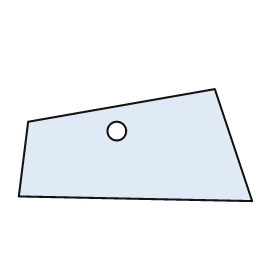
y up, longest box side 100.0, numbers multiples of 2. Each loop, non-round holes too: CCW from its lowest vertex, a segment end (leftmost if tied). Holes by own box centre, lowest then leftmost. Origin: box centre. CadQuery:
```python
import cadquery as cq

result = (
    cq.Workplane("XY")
    .moveTo(50.0, -24.0)
    .lineTo(34.0, 24.0)
    .lineTo(-46.0, 10.0)
    .lineTo(-50.0, -22.0)
    .close()
    .moveTo(-8.0, 6.0)
    .circle(4.0)
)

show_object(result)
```